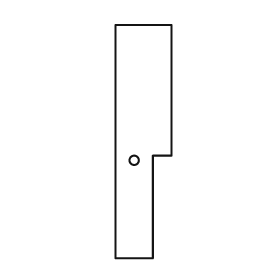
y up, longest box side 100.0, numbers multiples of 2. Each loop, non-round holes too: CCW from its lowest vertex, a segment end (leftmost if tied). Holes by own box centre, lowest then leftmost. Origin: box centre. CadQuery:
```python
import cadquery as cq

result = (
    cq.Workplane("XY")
    .moveTo(-12.0, -50.0)
    .lineTo(4.0, -50.0)
    .lineTo(4.0, -6.0)
    .lineTo(12.0, -6.0)
    .lineTo(12.0, 50.0)
    .lineTo(-12.0, 50.0)
    .close()
    .moveTo(-4.0, -8.0)
    .circle(2.0)
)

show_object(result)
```